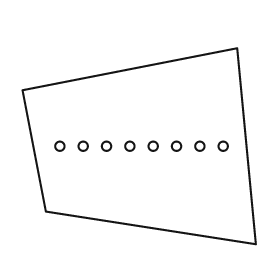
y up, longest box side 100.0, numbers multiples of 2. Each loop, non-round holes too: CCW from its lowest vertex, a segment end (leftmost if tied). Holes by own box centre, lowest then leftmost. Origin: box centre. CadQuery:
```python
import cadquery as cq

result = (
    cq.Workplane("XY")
    .moveTo(50.0, -42.0)
    .lineTo(42.0, 42.0)
    .lineTo(-50.0, 24.0)
    .lineTo(-40.0, -28.0)
    .close()
    .moveTo(-34.0, 0.0)
    .circle(2.0)
    .moveTo(-24.0, 0.0)
    .circle(2.0)
    .moveTo(-14.0, 0.0)
    .circle(2.0)
    .moveTo(-4.0, 0.0)
    .circle(2.0)
    .moveTo(6.0, 0.0)
    .circle(2.0)
    .moveTo(16.0, 0.0)
    .circle(2.0)
    .moveTo(26.0, 0.0)
    .circle(2.0)
    .moveTo(36.0, 0.0)
    .circle(2.0)
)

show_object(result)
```